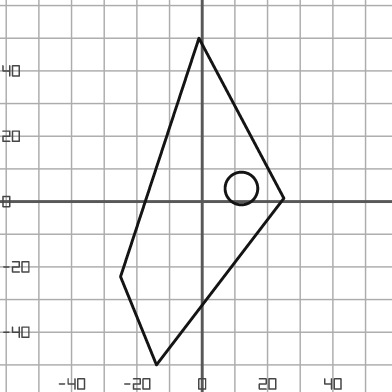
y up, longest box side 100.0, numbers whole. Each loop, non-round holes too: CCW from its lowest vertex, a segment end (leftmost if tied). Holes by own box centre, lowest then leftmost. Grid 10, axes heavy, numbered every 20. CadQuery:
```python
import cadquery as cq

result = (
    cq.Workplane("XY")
    .moveTo(-14.0, -50.0)
    .lineTo(25.0, 1.0)
    .lineTo(-1.0, 50.0)
    .lineTo(-25.0, -23.0)
    .close()
    .moveTo(12.0, 4.0)
    .circle(5.0)
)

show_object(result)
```